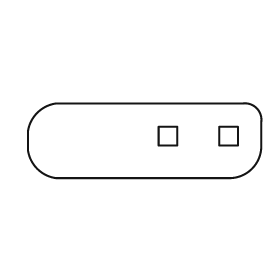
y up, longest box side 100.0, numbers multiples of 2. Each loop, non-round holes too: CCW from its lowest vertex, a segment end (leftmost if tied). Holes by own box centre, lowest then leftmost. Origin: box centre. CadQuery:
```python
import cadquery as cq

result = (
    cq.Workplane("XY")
    .moveTo(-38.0, -16.0)
    .lineTo(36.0, -16.0)
    .threePointArc((46.0, -12.0), (50.0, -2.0))
    .lineTo(50.0, 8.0)
    .threePointArc((48.0, 14.0), (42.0, 16.0))
    .lineTo(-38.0, 16.0)
    .threePointArc((-46.0, 12.0), (-50.0, 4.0))
    .lineTo(-50.0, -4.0)
    .threePointArc((-46.0, -12.0), (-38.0, -16.0))
    .close()
    .moveTo(6.0, -2.0)
    .lineTo(14.0, -2.0)
    .lineTo(14.0, 6.0)
    .lineTo(6.0, 6.0)
    .close()
    .moveTo(32.0, -2.0)
    .lineTo(40.0, -2.0)
    .lineTo(40.0, 6.0)
    .lineTo(32.0, 6.0)
    .close()
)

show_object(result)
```